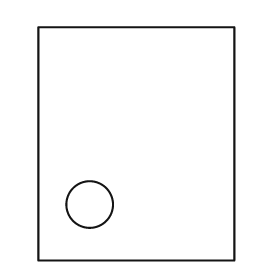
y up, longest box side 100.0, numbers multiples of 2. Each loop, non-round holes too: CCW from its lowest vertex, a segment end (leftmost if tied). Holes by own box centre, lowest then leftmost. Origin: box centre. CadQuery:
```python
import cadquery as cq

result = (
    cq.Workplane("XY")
    .moveTo(-42.0, -50.0)
    .lineTo(42.0, -50.0)
    .lineTo(42.0, 50.0)
    .lineTo(-42.0, 50.0)
    .close()
    .moveTo(-20.0, -26.0)
    .circle(10.0)
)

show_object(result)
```